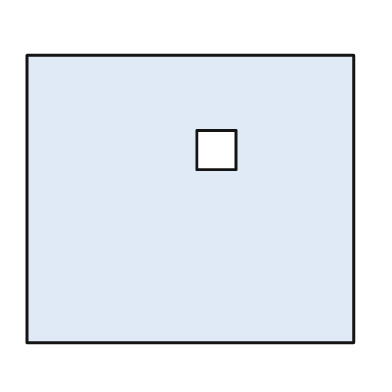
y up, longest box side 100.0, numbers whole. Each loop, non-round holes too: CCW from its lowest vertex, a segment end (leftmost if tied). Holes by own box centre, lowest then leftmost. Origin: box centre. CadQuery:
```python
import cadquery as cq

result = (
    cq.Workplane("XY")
    .moveTo(-50.0, -44.0)
    .lineTo(50.0, -44.0)
    .lineTo(50.0, 44.0)
    .lineTo(-50.0, 44.0)
    .close()
    .moveTo(2.0, 9.0)
    .lineTo(14.0, 9.0)
    .lineTo(14.0, 21.0)
    .lineTo(2.0, 21.0)
    .close()
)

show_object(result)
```